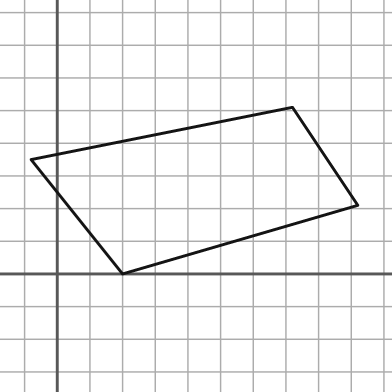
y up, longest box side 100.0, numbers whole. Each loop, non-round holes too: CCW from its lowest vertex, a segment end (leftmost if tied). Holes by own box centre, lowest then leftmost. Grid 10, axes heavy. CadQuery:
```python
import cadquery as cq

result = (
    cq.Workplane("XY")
    .moveTo(20.0, 0.0)
    .lineTo(92.0, 21.0)
    .lineTo(72.0, 51.0)
    .lineTo(-8.0, 35.0)
    .close()
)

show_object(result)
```